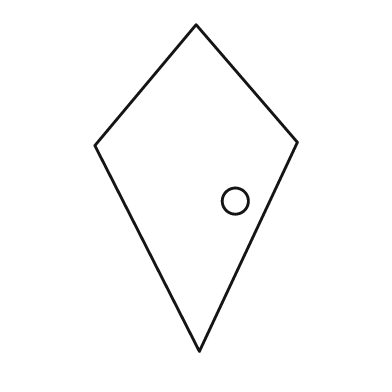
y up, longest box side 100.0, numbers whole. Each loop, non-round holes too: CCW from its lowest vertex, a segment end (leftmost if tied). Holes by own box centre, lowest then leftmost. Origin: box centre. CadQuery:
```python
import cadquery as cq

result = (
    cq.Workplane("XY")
    .moveTo(1.0, -50.0)
    .lineTo(31.0, 14.0)
    .lineTo(0.0, 50.0)
    .lineTo(-31.0, 13.0)
    .close()
    .moveTo(12.0, -4.0)
    .circle(4.0)
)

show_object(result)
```